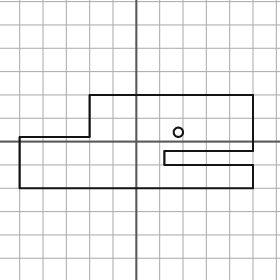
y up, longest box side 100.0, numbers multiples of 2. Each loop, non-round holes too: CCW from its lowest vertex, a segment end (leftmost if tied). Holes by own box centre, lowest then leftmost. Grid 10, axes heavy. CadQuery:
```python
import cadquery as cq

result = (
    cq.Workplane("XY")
    .moveTo(-50.0, -20.0)
    .lineTo(50.0, -20.0)
    .lineTo(50.0, -10.0)
    .lineTo(12.0, -10.0)
    .lineTo(12.0, -4.0)
    .lineTo(50.0, -4.0)
    .lineTo(50.0, 20.0)
    .lineTo(-20.0, 20.0)
    .lineTo(-20.0, 2.0)
    .lineTo(-50.0, 2.0)
    .close()
    .moveTo(18.0, 4.0)
    .circle(2.0)
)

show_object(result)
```